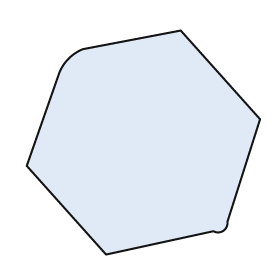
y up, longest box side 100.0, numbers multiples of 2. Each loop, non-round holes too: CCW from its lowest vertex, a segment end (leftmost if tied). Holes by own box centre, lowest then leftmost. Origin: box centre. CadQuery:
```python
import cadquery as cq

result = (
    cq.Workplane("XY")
    .moveTo(-16.0, -48.0)
    .lineTo(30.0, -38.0)
    .threePointArc((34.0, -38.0), (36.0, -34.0))
    .lineTo(50.0, 10.0)
    .lineTo(16.0, 48.0)
    .lineTo(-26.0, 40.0)
    .threePointArc((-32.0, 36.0), (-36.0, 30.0))
    .lineTo(-50.0, -10.0)
    .close()
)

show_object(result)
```